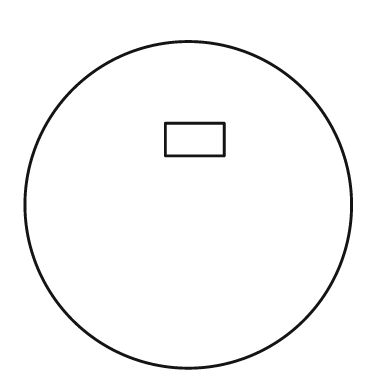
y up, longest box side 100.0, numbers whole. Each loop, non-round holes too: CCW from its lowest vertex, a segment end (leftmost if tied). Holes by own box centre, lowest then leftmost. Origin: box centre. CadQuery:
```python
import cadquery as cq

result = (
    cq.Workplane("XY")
    .moveTo(0.0, 0.0)
    .circle(50.0)
    .moveTo(-7.0, 15.0)
    .lineTo(11.0, 15.0)
    .lineTo(11.0, 25.0)
    .lineTo(-7.0, 25.0)
    .close()
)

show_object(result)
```